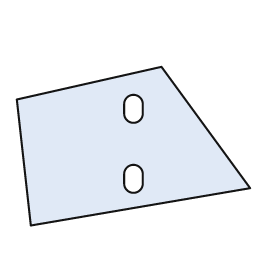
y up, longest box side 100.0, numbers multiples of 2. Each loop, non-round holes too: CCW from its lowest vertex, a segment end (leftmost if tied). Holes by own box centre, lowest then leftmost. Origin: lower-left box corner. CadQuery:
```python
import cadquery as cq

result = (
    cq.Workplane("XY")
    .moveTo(6.0, 0.0)
    .lineTo(100.0, 16.0)
    .lineTo(62.0, 68.0)
    .lineTo(0.0, 54.0)
    .close()
    .moveTo(46.0, 18.0)
    .threePointArc((50.0, 14.0), (54.0, 18.0))
    .lineTo(54.0, 22.0)
    .threePointArc((50.0, 26.0), (46.0, 22.0))
    .close()
    .moveTo(46.0, 48.0)
    .threePointArc((50.0, 44.0), (54.0, 48.0))
    .lineTo(54.0, 52.0)
    .threePointArc((50.0, 56.0), (46.0, 52.0))
    .close()
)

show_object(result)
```